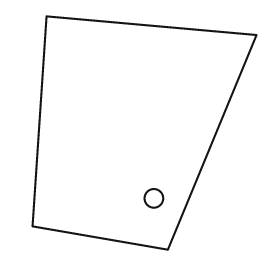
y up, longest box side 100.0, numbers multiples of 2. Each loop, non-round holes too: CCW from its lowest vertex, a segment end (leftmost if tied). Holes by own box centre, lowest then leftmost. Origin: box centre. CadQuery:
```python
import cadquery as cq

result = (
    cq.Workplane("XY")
    .moveTo(10.0, -50.0)
    .lineTo(48.0, 42.0)
    .lineTo(-42.0, 50.0)
    .lineTo(-48.0, -40.0)
    .close()
    .moveTo(4.0, -28.0)
    .circle(4.0)
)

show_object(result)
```